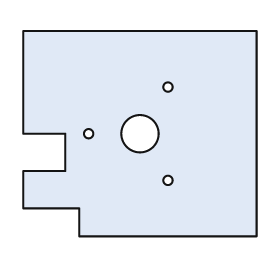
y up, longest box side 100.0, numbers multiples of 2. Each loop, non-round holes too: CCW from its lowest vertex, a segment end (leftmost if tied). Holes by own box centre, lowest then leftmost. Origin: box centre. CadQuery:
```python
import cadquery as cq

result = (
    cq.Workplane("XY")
    .moveTo(-26.0, -44.0)
    .lineTo(50.0, -44.0)
    .lineTo(50.0, 44.0)
    .lineTo(-50.0, 44.0)
    .lineTo(-50.0, 0.0)
    .lineTo(-32.0, 0.0)
    .lineTo(-32.0, -16.0)
    .lineTo(-50.0, -16.0)
    .lineTo(-50.0, -32.0)
    .lineTo(-26.0, -32.0)
    .close()
    .moveTo(12.0, -20.0)
    .circle(2.0)
    .moveTo(-22.0, 0.0)
    .circle(2.0)
    .moveTo(0.0, 0.0)
    .circle(8.0)
    .moveTo(12.0, 20.0)
    .circle(2.0)
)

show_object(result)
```